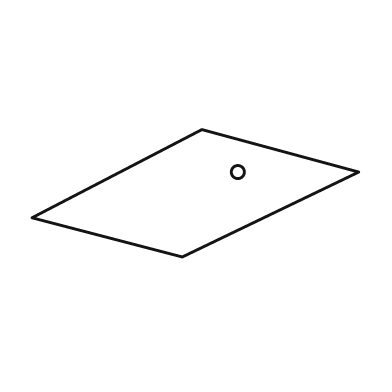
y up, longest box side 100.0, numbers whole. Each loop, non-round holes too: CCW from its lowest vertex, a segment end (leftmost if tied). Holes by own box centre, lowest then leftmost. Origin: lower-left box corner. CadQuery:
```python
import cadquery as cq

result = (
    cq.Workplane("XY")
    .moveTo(46.0, 0.0)
    .lineTo(100.0, 26.0)
    .lineTo(52.0, 39.0)
    .lineTo(0.0, 12.0)
    .close()
    .moveTo(63.0, 26.0)
    .circle(2.0)
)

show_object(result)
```